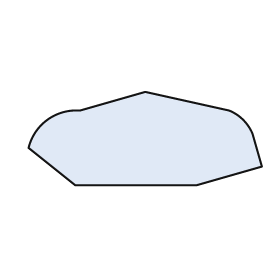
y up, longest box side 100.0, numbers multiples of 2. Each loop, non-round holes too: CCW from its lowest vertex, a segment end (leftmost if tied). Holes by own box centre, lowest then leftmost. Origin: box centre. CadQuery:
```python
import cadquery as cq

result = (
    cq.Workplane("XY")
    .moveTo(-30.0, -20.0)
    .lineTo(22.0, -20.0)
    .lineTo(50.0, -12.0)
    .lineTo(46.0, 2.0)
    .threePointArc((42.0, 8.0), (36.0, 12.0))
    .lineTo(0.0, 20.0)
    .lineTo(-28.0, 12.0)
    .threePointArc((-42.0, 8.0), (-50.0, -4.0))
    .close()
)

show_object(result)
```